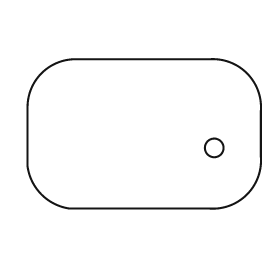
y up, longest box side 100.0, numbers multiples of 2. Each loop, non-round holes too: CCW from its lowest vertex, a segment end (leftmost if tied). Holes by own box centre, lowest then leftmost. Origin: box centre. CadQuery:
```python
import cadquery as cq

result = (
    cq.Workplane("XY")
    .moveTo(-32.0, -32.0)
    .lineTo(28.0, -32.0)
    .threePointArc((44.0, -26.0), (50.0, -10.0))
    .lineTo(50.0, 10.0)
    .threePointArc((44.0, 26.0), (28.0, 32.0))
    .lineTo(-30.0, 32.0)
    .threePointArc((-44.0, 26.0), (-50.0, 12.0))
    .lineTo(-50.0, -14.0)
    .threePointArc((-44.0, -26.0), (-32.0, -32.0))
    .close()
    .moveTo(30.0, -6.0)
    .circle(4.0)
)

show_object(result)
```